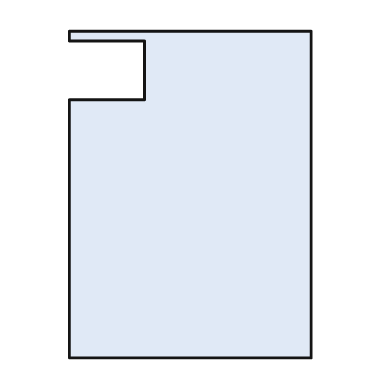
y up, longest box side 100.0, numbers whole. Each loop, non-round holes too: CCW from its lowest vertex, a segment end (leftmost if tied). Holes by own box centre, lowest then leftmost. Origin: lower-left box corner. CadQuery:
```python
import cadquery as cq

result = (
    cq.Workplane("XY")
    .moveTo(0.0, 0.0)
    .lineTo(74.0, 0.0)
    .lineTo(74.0, 100.0)
    .lineTo(0.0, 100.0)
    .lineTo(0.0, 97.0)
    .lineTo(23.0, 97.0)
    .lineTo(23.0, 79.0)
    .lineTo(0.0, 79.0)
    .close()
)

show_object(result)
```